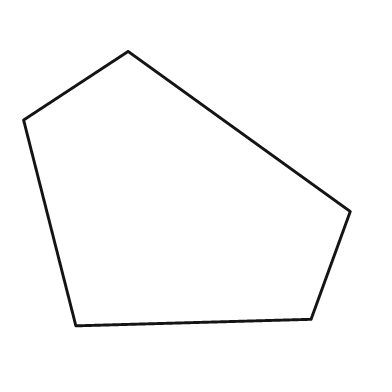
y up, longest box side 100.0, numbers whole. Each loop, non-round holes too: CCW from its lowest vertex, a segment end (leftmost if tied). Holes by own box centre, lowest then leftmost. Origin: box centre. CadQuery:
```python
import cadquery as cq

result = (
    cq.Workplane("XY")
    .moveTo(-34.0, -42.0)
    .lineTo(38.0, -40.0)
    .lineTo(50.0, -7.0)
    .lineTo(-18.0, 42.0)
    .lineTo(-50.0, 21.0)
    .close()
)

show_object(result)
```